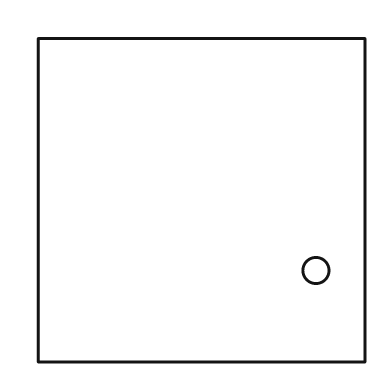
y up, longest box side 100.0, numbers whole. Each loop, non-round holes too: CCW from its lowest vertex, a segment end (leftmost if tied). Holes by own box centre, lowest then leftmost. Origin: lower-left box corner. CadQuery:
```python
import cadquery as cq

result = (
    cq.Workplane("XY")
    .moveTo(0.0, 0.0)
    .lineTo(100.0, 0.0)
    .lineTo(100.0, 99.0)
    .lineTo(0.0, 99.0)
    .close()
    .moveTo(85.0, 28.0)
    .circle(4.0)
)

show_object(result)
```